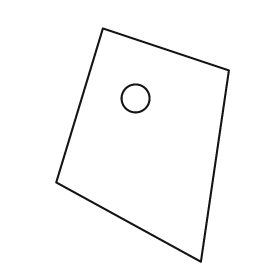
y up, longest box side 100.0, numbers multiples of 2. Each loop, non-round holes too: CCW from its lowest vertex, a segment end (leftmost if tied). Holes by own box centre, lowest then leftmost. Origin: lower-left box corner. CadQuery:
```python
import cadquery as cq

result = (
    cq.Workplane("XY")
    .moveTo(62.0, 0.0)
    .lineTo(74.0, 82.0)
    .lineTo(20.0, 100.0)
    .lineTo(0.0, 34.0)
    .close()
    .moveTo(34.0, 70.0)
    .circle(6.0)
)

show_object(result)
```